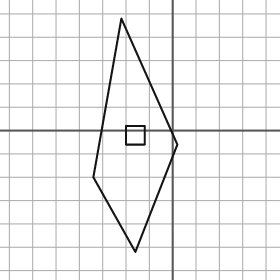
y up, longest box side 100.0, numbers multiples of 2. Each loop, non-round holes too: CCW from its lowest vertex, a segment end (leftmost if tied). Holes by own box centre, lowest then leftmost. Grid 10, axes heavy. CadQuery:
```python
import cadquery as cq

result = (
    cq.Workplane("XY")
    .moveTo(-16.0, -52.0)
    .lineTo(2.0, -6.0)
    .lineTo(-22.0, 48.0)
    .lineTo(-34.0, -20.0)
    .close()
    .moveTo(-20.0, -6.0)
    .lineTo(-12.0, -6.0)
    .lineTo(-12.0, 2.0)
    .lineTo(-20.0, 2.0)
    .close()
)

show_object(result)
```